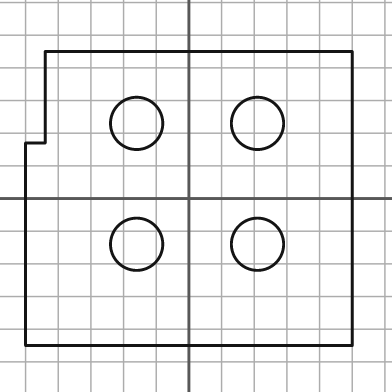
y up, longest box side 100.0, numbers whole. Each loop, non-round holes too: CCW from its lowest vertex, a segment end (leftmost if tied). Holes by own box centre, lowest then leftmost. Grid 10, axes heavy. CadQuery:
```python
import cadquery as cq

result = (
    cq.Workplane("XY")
    .moveTo(-50.0, -45.0)
    .lineTo(50.0, -45.0)
    .lineTo(50.0, 45.0)
    .lineTo(-44.0, 45.0)
    .lineTo(-44.0, 17.0)
    .lineTo(-50.0, 17.0)
    .close()
    .moveTo(-16.0, -14.0)
    .circle(8.0)
    .moveTo(21.0, -14.0)
    .circle(8.0)
    .moveTo(-16.0, 23.0)
    .circle(8.0)
    .moveTo(21.0, 23.0)
    .circle(8.0)
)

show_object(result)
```